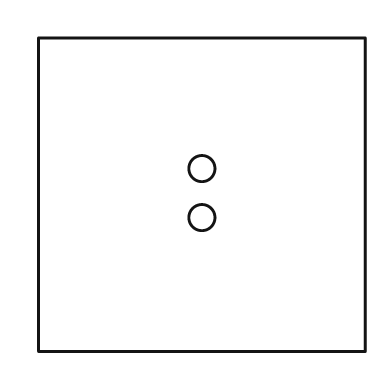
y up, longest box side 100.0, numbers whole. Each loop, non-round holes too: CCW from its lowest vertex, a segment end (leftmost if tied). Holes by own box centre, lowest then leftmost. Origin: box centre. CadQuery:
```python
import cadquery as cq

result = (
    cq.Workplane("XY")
    .moveTo(-50.0, -48.0)
    .lineTo(50.0, -48.0)
    .lineTo(50.0, 48.0)
    .lineTo(-50.0, 48.0)
    .close()
    .moveTo(0.0, -7.0)
    .circle(4.0)
    .moveTo(0.0, 8.0)
    .circle(4.0)
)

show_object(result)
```